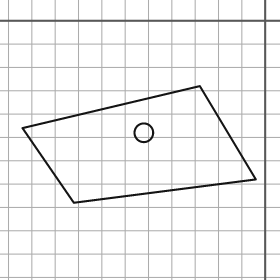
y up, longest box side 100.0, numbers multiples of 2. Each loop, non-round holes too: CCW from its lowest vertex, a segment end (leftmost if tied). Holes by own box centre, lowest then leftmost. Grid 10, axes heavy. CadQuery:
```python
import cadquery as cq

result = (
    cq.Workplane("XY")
    .moveTo(-82.0, -78.0)
    .lineTo(-4.0, -68.0)
    .lineTo(-28.0, -28.0)
    .lineTo(-104.0, -46.0)
    .close()
    .moveTo(-52.0, -48.0)
    .circle(4.0)
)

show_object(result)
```